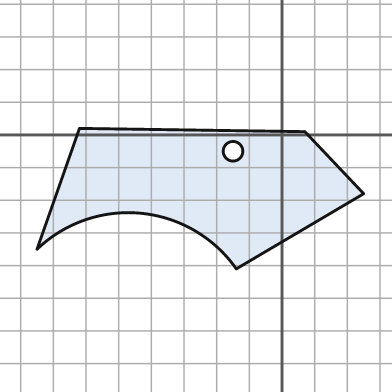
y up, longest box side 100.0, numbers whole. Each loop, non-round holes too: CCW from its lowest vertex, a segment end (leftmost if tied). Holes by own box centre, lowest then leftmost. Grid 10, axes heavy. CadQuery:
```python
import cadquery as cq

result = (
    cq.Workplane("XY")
    .moveTo(-14.0, -41.0)
    .lineTo(25.0, -18.0)
    .lineTo(7.0, 1.0)
    .lineTo(-62.0, 2.0)
    .lineTo(-75.0, -35.0)
    .threePointArc((-43.0, -24.0), (-14.0, -41.0))
    .close()
    .moveTo(-15.0, -5.0)
    .circle(3.0)
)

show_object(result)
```